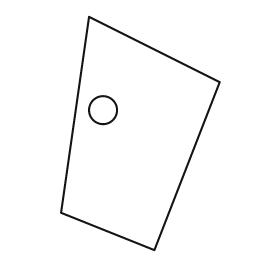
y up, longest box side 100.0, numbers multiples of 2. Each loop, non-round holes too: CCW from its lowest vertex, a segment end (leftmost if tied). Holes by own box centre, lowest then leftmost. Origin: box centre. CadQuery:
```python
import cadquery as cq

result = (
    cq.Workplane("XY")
    .moveTo(6.0, -50.0)
    .lineTo(34.0, 22.0)
    .lineTo(-22.0, 50.0)
    .lineTo(-34.0, -34.0)
    .close()
    .moveTo(-16.0, 10.0)
    .circle(6.0)
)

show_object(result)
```